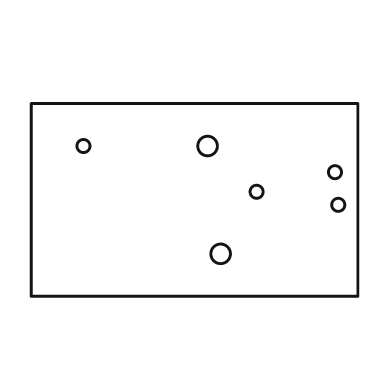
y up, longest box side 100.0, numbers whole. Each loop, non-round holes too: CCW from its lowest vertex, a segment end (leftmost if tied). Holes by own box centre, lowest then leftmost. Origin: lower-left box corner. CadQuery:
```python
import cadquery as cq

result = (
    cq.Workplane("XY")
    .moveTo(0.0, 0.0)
    .lineTo(100.0, 0.0)
    .lineTo(100.0, 59.0)
    .lineTo(0.0, 59.0)
    .close()
    .moveTo(58.0, 13.0)
    .circle(3.0)
    .moveTo(94.0, 28.0)
    .circle(2.0)
    .moveTo(69.0, 32.0)
    .circle(2.0)
    .moveTo(93.0, 38.0)
    .circle(2.0)
    .moveTo(16.0, 46.0)
    .circle(2.0)
    .moveTo(54.0, 46.0)
    .circle(3.0)
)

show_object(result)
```